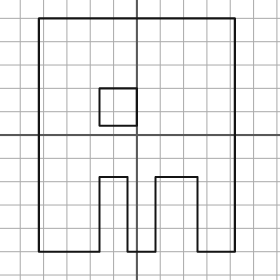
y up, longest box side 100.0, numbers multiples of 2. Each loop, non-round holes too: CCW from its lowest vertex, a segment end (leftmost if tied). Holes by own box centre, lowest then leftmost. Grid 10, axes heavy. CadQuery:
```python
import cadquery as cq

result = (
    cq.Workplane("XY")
    .moveTo(-42.0, -50.0)
    .lineTo(-16.0, -50.0)
    .lineTo(-16.0, -18.0)
    .lineTo(-4.0, -18.0)
    .lineTo(-4.0, -50.0)
    .lineTo(8.0, -50.0)
    .lineTo(8.0, -18.0)
    .lineTo(26.0, -18.0)
    .lineTo(26.0, -50.0)
    .lineTo(42.0, -50.0)
    .lineTo(42.0, 50.0)
    .lineTo(-42.0, 50.0)
    .close()
    .moveTo(-16.0, 4.0)
    .lineTo(0.0, 4.0)
    .lineTo(0.0, 20.0)
    .lineTo(-16.0, 20.0)
    .close()
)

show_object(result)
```